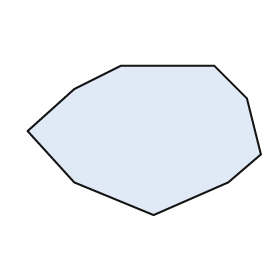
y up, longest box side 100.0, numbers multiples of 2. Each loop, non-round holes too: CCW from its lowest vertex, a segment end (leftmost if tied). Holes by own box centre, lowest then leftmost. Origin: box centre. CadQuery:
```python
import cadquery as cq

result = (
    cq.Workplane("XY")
    .moveTo(4.0, -32.0)
    .lineTo(36.0, -18.0)
    .lineTo(50.0, -6.0)
    .lineTo(44.0, 18.0)
    .lineTo(30.0, 32.0)
    .lineTo(-10.0, 32.0)
    .lineTo(-30.0, 22.0)
    .lineTo(-50.0, 4.0)
    .lineTo(-30.0, -18.0)
    .close()
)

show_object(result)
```